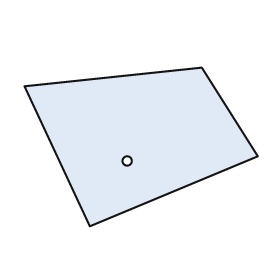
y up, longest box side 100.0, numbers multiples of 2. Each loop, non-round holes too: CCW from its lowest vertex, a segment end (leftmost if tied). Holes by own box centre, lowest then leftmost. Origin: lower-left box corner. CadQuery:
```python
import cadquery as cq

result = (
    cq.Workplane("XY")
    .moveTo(28.0, 0.0)
    .lineTo(100.0, 30.0)
    .lineTo(76.0, 68.0)
    .lineTo(0.0, 60.0)
    .close()
    .moveTo(44.0, 28.0)
    .circle(2.0)
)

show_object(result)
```